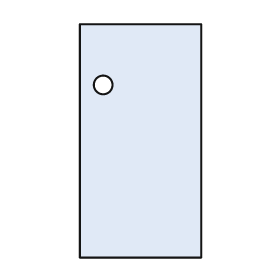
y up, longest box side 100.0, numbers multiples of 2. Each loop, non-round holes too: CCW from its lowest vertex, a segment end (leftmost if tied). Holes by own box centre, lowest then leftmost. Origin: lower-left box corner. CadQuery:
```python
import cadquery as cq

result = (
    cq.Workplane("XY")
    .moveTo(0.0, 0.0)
    .lineTo(52.0, 0.0)
    .lineTo(52.0, 100.0)
    .lineTo(0.0, 100.0)
    .close()
    .moveTo(10.0, 74.0)
    .circle(4.0)
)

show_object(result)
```